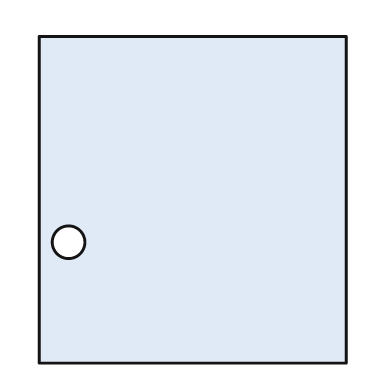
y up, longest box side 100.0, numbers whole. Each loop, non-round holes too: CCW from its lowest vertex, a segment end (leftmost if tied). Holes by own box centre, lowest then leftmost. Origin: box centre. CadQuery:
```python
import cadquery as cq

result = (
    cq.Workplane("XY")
    .moveTo(-47.0, -50.0)
    .lineTo(47.0, -50.0)
    .lineTo(47.0, 50.0)
    .lineTo(-47.0, 50.0)
    .close()
    .moveTo(-38.0, -13.0)
    .circle(5.0)
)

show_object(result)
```